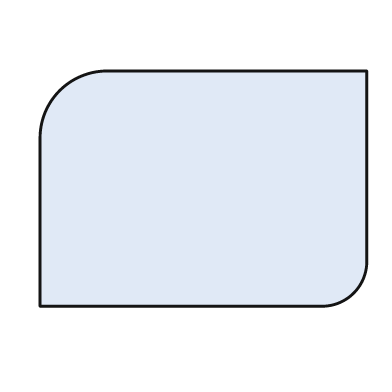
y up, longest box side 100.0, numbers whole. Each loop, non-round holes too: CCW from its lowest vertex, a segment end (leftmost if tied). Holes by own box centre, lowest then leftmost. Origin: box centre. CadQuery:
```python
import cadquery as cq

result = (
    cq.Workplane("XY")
    .moveTo(-50.0, -36.0)
    .lineTo(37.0, -36.0)
    .threePointArc((46.0, -32.0), (50.0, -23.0))
    .lineTo(50.0, 36.0)
    .lineTo(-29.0, 36.0)
    .threePointArc((-44.0, 30.0), (-50.0, 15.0))
    .close()
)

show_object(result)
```